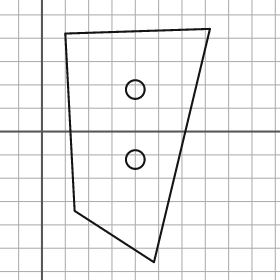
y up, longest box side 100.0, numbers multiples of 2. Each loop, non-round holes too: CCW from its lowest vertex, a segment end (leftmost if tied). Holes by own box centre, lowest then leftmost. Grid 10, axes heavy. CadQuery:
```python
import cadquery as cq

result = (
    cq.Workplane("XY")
    .moveTo(48.0, -56.0)
    .lineTo(72.0, 44.0)
    .lineTo(10.0, 42.0)
    .lineTo(14.0, -34.0)
    .close()
    .moveTo(40.0, -12.0)
    .circle(4.0)
    .moveTo(40.0, 18.0)
    .circle(4.0)
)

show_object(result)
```